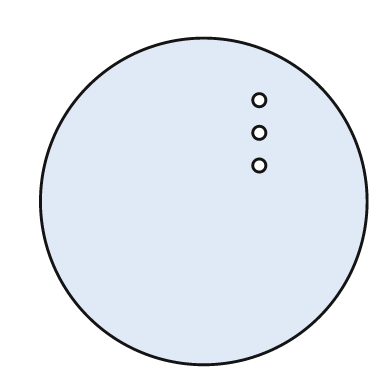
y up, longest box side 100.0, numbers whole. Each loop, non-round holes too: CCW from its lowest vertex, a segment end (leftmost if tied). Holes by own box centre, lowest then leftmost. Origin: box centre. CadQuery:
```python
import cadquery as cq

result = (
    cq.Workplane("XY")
    .moveTo(0.0, 0.0)
    .circle(50.0)
    .moveTo(17.0, 11.0)
    .circle(2.0)
    .moveTo(17.0, 21.0)
    .circle(2.0)
    .moveTo(17.0, 31.0)
    .circle(2.0)
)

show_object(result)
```